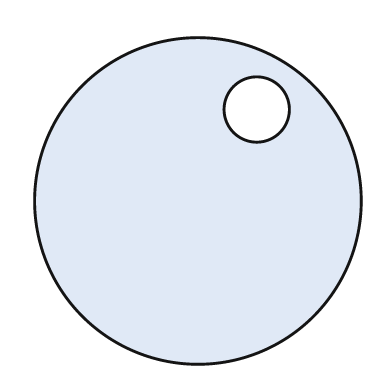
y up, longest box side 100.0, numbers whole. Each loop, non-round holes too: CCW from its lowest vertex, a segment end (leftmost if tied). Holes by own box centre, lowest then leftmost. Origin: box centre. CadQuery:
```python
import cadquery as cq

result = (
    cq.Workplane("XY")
    .moveTo(0.0, 0.0)
    .circle(50.0)
    .moveTo(18.0, 28.0)
    .circle(10.0)
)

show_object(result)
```